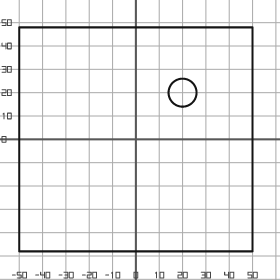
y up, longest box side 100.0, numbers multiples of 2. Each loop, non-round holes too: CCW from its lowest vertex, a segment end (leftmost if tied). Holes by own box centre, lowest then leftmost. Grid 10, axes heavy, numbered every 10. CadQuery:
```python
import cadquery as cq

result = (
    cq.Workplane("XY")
    .moveTo(-50.0, -48.0)
    .lineTo(50.0, -48.0)
    .lineTo(50.0, 48.0)
    .lineTo(-50.0, 48.0)
    .close()
    .moveTo(20.0, 20.0)
    .circle(6.0)
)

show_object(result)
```